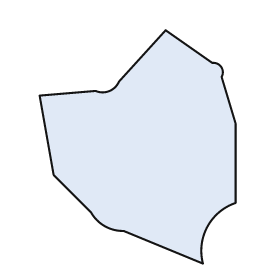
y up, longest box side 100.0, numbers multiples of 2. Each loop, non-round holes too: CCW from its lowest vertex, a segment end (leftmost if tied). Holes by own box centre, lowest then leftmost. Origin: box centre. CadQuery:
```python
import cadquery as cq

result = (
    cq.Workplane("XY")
    .moveTo(28.0, -50.0)
    .threePointArc((30.0, -34.0), (42.0, -24.0))
    .lineTo(42.0, 10.0)
    .lineTo(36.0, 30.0)
    .threePointArc((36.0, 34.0), (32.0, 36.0))
    .lineTo(12.0, 50.0)
    .lineTo(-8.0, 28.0)
    .threePointArc((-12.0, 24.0), (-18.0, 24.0))
    .lineTo(-42.0, 22.0)
    .lineTo(-36.0, -12.0)
    .lineTo(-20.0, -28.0)
    .threePointArc((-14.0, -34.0), (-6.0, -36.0))
    .close()
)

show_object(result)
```